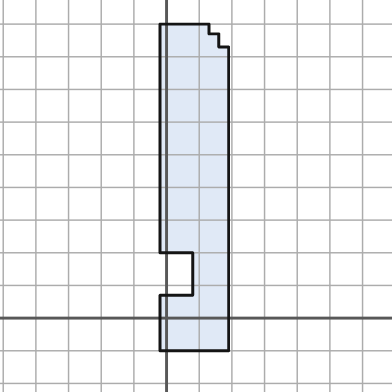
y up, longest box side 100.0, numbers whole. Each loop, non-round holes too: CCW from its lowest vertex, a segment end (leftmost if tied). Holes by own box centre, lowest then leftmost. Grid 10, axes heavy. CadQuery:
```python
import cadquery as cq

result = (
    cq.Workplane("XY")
    .moveTo(-2.0, -10.0)
    .lineTo(19.0, -10.0)
    .lineTo(19.0, 83.0)
    .lineTo(16.0, 83.0)
    .lineTo(16.0, 87.0)
    .lineTo(13.0, 87.0)
    .lineTo(13.0, 90.0)
    .lineTo(-2.0, 90.0)
    .lineTo(-2.0, 20.0)
    .lineTo(8.0, 20.0)
    .lineTo(8.0, 7.0)
    .lineTo(-2.0, 7.0)
    .close()
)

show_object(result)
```